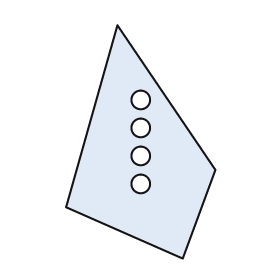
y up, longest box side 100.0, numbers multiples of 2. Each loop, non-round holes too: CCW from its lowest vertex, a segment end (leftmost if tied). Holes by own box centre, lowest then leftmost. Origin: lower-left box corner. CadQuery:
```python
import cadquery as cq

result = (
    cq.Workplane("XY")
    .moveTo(50.0, 0.0)
    .lineTo(64.0, 38.0)
    .lineTo(22.0, 100.0)
    .lineTo(0.0, 22.0)
    .close()
    .moveTo(32.0, 32.0)
    .circle(4.0)
    .moveTo(32.0, 44.0)
    .circle(4.0)
    .moveTo(32.0, 56.0)
    .circle(4.0)
    .moveTo(32.0, 68.0)
    .circle(4.0)
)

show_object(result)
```